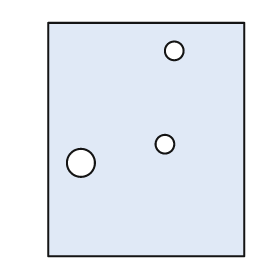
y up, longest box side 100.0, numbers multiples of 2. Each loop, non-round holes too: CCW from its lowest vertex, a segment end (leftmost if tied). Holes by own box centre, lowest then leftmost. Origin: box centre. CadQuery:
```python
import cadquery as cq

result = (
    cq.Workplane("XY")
    .moveTo(-42.0, -50.0)
    .lineTo(42.0, -50.0)
    .lineTo(42.0, 50.0)
    .lineTo(-42.0, 50.0)
    .close()
    .moveTo(-28.0, -10.0)
    .circle(6.0)
    .moveTo(8.0, -2.0)
    .circle(4.0)
    .moveTo(12.0, 38.0)
    .circle(4.0)
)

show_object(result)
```